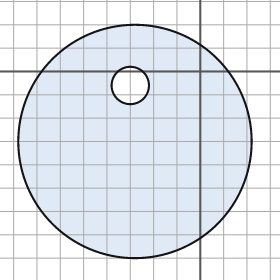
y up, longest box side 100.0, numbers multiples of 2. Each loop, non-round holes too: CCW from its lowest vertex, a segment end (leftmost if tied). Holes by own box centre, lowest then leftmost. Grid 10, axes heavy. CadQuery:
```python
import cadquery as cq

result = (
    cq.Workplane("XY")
    .moveTo(-28.0, -30.0)
    .circle(50.0)
    .moveTo(-30.0, -6.0)
    .circle(8.0)
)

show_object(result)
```